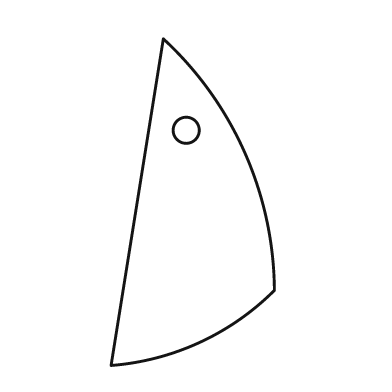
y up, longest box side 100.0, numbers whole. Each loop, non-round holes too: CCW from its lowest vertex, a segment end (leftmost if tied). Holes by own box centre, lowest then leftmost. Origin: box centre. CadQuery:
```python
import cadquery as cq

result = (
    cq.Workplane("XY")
    .moveTo(-25.0, -50.0)
    .threePointArc((2.0, -43.0), (25.0, -27.0))
    .threePointArc((16.0, 15.0), (-9.0, 50.0))
    .close()
    .moveTo(-2.0, 22.0)
    .circle(4.0)
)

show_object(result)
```